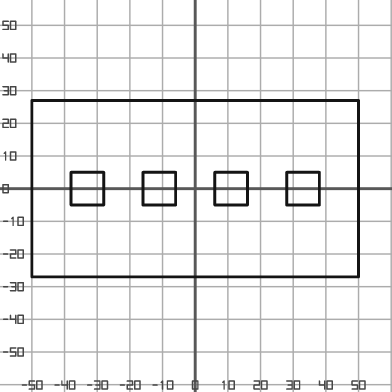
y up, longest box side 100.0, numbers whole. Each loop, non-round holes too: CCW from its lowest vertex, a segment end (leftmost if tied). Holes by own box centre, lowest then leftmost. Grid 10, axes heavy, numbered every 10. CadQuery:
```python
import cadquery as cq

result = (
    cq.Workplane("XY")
    .moveTo(-50.0, -27.0)
    .lineTo(50.0, -27.0)
    .lineTo(50.0, 27.0)
    .lineTo(-50.0, 27.0)
    .close()
    .moveTo(-38.0, -5.0)
    .lineTo(-28.0, -5.0)
    .lineTo(-28.0, 5.0)
    .lineTo(-38.0, 5.0)
    .close()
    .moveTo(-16.0, -5.0)
    .lineTo(-6.0, -5.0)
    .lineTo(-6.0, 5.0)
    .lineTo(-16.0, 5.0)
    .close()
    .moveTo(6.0, -5.0)
    .lineTo(16.0, -5.0)
    .lineTo(16.0, 5.0)
    .lineTo(6.0, 5.0)
    .close()
    .moveTo(28.0, -5.0)
    .lineTo(38.0, -5.0)
    .lineTo(38.0, 5.0)
    .lineTo(28.0, 5.0)
    .close()
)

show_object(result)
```